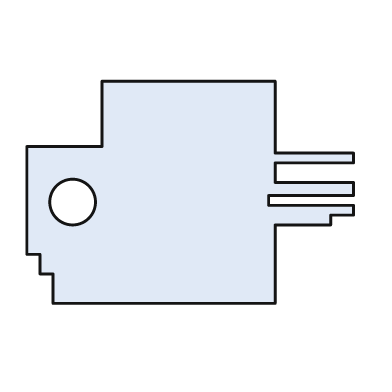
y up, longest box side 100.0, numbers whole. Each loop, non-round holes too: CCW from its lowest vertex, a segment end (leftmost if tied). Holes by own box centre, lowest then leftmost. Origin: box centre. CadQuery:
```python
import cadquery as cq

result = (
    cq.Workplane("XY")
    .moveTo(-42.0, -34.0)
    .lineTo(26.0, -34.0)
    .lineTo(26.0, -10.0)
    .lineTo(43.0, -10.0)
    .lineTo(43.0, -7.0)
    .lineTo(50.0, -7.0)
    .lineTo(50.0, -4.0)
    .lineTo(24.0, -4.0)
    .lineTo(24.0, -1.0)
    .lineTo(50.0, -1.0)
    .lineTo(50.0, 3.0)
    .lineTo(26.0, 3.0)
    .lineTo(26.0, 9.0)
    .lineTo(50.0, 9.0)
    .lineTo(50.0, 12.0)
    .lineTo(26.0, 12.0)
    .lineTo(26.0, 34.0)
    .lineTo(-27.0, 34.0)
    .lineTo(-27.0, 14.0)
    .lineTo(-50.0, 14.0)
    .lineTo(-50.0, -19.0)
    .lineTo(-46.0, -19.0)
    .lineTo(-46.0, -25.0)
    .lineTo(-42.0, -25.0)
    .close()
    .moveTo(-36.0, -3.0)
    .circle(7.0)
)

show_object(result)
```